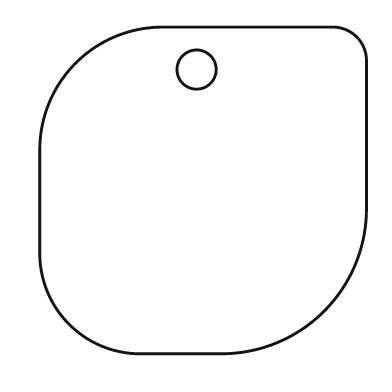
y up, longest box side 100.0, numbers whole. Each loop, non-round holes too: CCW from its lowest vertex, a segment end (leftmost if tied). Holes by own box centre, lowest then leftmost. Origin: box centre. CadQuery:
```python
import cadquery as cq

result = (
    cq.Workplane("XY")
    .moveTo(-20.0, -50.0)
    .lineTo(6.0, -50.0)
    .threePointArc((37.0, -37.0), (50.0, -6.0))
    .lineTo(50.0, 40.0)
    .threePointArc((47.0, 47.0), (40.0, 50.0))
    .lineTo(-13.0, 50.0)
    .threePointArc((-39.0, 39.0), (-50.0, 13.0))
    .lineTo(-50.0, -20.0)
    .threePointArc((-41.0, -41.0), (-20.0, -50.0))
    .close()
    .moveTo(-2.0, 37.0)
    .circle(6.0)
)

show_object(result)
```